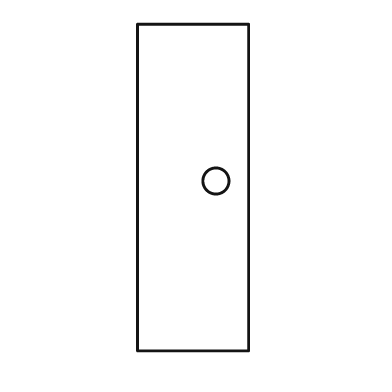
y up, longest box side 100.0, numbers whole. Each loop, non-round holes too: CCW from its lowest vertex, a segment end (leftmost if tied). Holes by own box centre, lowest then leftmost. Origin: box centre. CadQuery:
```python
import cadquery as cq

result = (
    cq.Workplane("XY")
    .moveTo(-17.0, -50.0)
    .lineTo(17.0, -50.0)
    .lineTo(17.0, 50.0)
    .lineTo(-17.0, 50.0)
    .close()
    .moveTo(7.0, 2.0)
    .circle(4.0)
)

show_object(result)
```